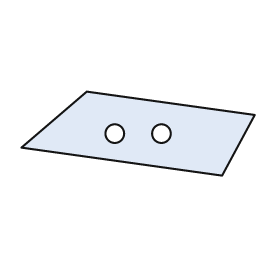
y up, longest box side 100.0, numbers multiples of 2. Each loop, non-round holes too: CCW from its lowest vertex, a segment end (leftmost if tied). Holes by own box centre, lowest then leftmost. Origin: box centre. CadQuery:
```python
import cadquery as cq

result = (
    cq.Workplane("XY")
    .moveTo(36.0, -18.0)
    .lineTo(50.0, 8.0)
    .lineTo(-22.0, 18.0)
    .lineTo(-50.0, -6.0)
    .close()
    .moveTo(-10.0, 0.0)
    .circle(4.0)
    .moveTo(10.0, 0.0)
    .circle(4.0)
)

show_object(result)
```